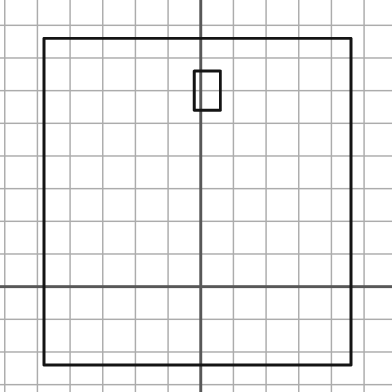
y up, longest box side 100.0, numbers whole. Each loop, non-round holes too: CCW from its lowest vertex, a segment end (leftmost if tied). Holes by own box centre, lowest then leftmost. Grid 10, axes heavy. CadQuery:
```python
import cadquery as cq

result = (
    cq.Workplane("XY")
    .moveTo(-48.0, -24.0)
    .lineTo(46.0, -24.0)
    .lineTo(46.0, 76.0)
    .lineTo(-48.0, 76.0)
    .close()
    .moveTo(-2.0, 54.0)
    .lineTo(6.0, 54.0)
    .lineTo(6.0, 66.0)
    .lineTo(-2.0, 66.0)
    .close()
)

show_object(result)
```